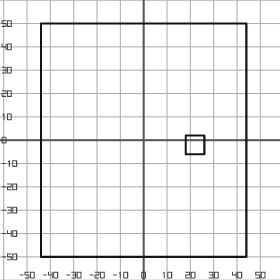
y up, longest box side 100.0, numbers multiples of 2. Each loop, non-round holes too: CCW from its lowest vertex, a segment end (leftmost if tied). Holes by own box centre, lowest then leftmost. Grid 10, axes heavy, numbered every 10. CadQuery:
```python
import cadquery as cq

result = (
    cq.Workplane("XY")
    .moveTo(-44.0, -50.0)
    .lineTo(44.0, -50.0)
    .lineTo(44.0, 50.0)
    .lineTo(-44.0, 50.0)
    .close()
    .moveTo(18.0, -6.0)
    .lineTo(26.0, -6.0)
    .lineTo(26.0, 2.0)
    .lineTo(18.0, 2.0)
    .close()
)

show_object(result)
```